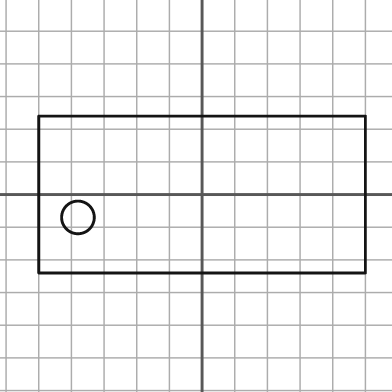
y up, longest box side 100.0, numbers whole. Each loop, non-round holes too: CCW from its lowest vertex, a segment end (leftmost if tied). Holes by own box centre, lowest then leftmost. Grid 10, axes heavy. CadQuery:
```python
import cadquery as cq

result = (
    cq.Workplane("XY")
    .moveTo(-50.0, -24.0)
    .lineTo(50.0, -24.0)
    .lineTo(50.0, 24.0)
    .lineTo(-50.0, 24.0)
    .close()
    .moveTo(-38.0, -7.0)
    .circle(5.0)
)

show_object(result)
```